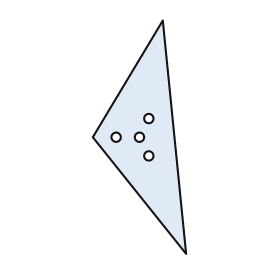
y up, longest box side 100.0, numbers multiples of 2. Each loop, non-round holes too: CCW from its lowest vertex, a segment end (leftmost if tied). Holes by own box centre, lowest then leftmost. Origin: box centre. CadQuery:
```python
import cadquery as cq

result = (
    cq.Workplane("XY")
    .moveTo(20.0, -50.0)
    .lineTo(10.0, 50.0)
    .lineTo(-20.0, 0.0)
    .close()
    .moveTo(4.0, -8.0)
    .circle(2.0)
    .moveTo(-10.0, 0.0)
    .circle(2.0)
    .moveTo(0.0, 0.0)
    .circle(2.0)
    .moveTo(4.0, 8.0)
    .circle(2.0)
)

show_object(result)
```